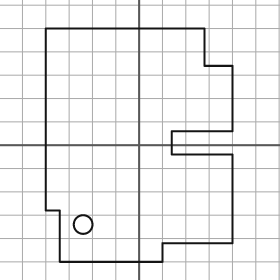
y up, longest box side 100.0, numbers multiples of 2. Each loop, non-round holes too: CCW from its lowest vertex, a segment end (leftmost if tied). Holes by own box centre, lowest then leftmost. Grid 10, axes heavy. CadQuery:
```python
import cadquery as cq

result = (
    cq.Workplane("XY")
    .moveTo(-34.0, -50.0)
    .lineTo(10.0, -50.0)
    .lineTo(10.0, -42.0)
    .lineTo(40.0, -42.0)
    .lineTo(40.0, -4.0)
    .lineTo(14.0, -4.0)
    .lineTo(14.0, 6.0)
    .lineTo(40.0, 6.0)
    .lineTo(40.0, 34.0)
    .lineTo(28.0, 34.0)
    .lineTo(28.0, 50.0)
    .lineTo(-40.0, 50.0)
    .lineTo(-40.0, -28.0)
    .lineTo(-34.0, -28.0)
    .close()
    .moveTo(-24.0, -34.0)
    .circle(4.0)
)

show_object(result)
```